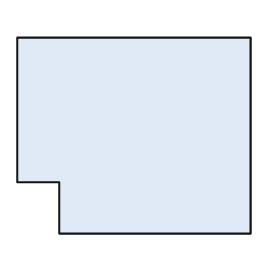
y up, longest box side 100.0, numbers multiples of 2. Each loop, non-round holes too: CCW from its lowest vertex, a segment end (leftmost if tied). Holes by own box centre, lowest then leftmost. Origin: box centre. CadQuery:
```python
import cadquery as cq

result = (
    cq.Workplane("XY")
    .moveTo(-32.0, -42.0)
    .lineTo(50.0, -42.0)
    .lineTo(50.0, 42.0)
    .lineTo(-50.0, 42.0)
    .lineTo(-50.0, -20.0)
    .lineTo(-32.0, -20.0)
    .close()
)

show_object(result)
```